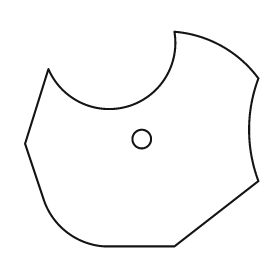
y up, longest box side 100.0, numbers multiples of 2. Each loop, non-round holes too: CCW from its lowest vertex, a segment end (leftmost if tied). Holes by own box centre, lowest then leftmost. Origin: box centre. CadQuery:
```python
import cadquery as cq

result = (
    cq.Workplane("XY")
    .moveTo(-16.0, -46.0)
    .lineTo(14.0, -46.0)
    .lineTo(50.0, -18.0)
    .threePointArc((46.0, 4.0), (50.0, 26.0))
    .threePointArc((34.0, 40.0), (14.0, 46.0))
    .threePointArc((-6.0, 14.0), (-40.0, 30.0))
    .lineTo(-50.0, -2.0)
    .lineTo(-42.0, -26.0)
    .threePointArc((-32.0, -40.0), (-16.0, -46.0))
    .close()
    .moveTo(0.0, 0.0)
    .circle(4.0)
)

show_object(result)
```